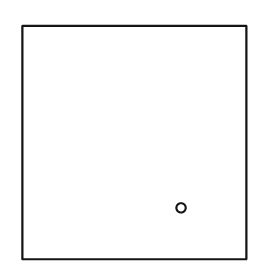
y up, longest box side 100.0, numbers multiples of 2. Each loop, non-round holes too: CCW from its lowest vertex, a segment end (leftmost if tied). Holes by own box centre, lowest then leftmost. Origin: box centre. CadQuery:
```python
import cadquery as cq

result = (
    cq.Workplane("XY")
    .moveTo(-48.0, -50.0)
    .lineTo(48.0, -50.0)
    .lineTo(48.0, 50.0)
    .lineTo(-48.0, 50.0)
    .close()
    .moveTo(20.0, -28.0)
    .circle(2.0)
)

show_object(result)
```